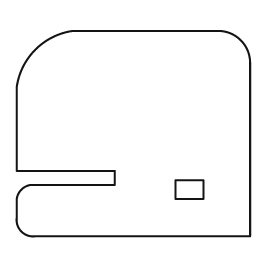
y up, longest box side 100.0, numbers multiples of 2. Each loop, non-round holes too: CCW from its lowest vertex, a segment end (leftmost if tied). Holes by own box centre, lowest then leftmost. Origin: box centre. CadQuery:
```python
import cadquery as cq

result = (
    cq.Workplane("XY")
    .moveTo(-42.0, -44.0)
    .lineTo(50.0, -44.0)
    .lineTo(50.0, 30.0)
    .threePointArc((46.0, 40.0), (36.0, 44.0))
    .lineTo(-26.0, 44.0)
    .threePointArc((-42.0, 36.0), (-50.0, 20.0))
    .lineTo(-50.0, -16.0)
    .lineTo(-8.0, -16.0)
    .lineTo(-8.0, -22.0)
    .lineTo(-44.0, -22.0)
    .threePointArc((-48.0, -24.0), (-50.0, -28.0))
    .lineTo(-50.0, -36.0)
    .threePointArc((-48.0, -42.0), (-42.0, -44.0))
    .close()
    .moveTo(18.0, -28.0)
    .lineTo(30.0, -28.0)
    .lineTo(30.0, -20.0)
    .lineTo(18.0, -20.0)
    .close()
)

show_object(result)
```